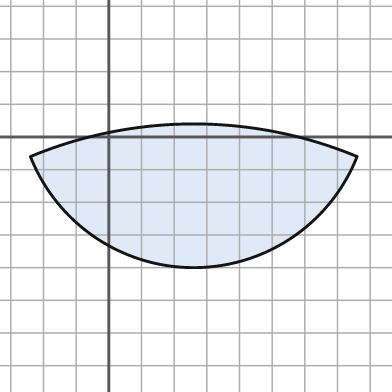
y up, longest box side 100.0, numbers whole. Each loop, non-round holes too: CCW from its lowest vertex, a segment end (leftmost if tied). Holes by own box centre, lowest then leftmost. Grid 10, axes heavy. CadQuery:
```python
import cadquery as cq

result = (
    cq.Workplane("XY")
    .moveTo(-24.0, -6.0)
    .threePointArc((26.0, -40.0), (76.0, -6.0))
    .threePointArc((26.0, 4.0), (-24.0, -6.0))
    .close()
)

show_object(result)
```